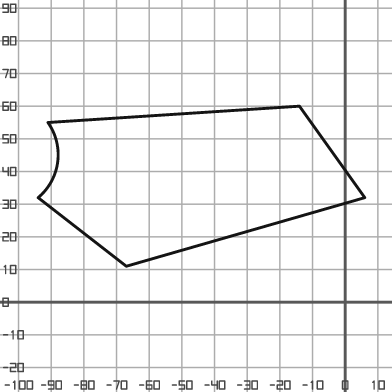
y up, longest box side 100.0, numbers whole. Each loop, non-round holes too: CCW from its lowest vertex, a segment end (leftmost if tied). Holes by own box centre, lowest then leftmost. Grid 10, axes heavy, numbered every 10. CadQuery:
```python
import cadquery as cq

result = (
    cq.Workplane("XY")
    .moveTo(-67.0, 11.0)
    .lineTo(6.0, 32.0)
    .lineTo(-14.0, 60.0)
    .lineTo(-91.0, 55.0)
    .threePointArc((-88.0, 43.0), (-94.0, 32.0))
    .close()
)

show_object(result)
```